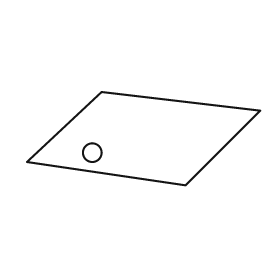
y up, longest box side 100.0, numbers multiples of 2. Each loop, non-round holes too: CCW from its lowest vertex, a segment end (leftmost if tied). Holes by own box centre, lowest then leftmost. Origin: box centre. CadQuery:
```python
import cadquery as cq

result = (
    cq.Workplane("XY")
    .moveTo(18.0, -20.0)
    .lineTo(50.0, 12.0)
    .lineTo(-18.0, 20.0)
    .lineTo(-50.0, -10.0)
    .close()
    .moveTo(-22.0, -6.0)
    .circle(4.0)
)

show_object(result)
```